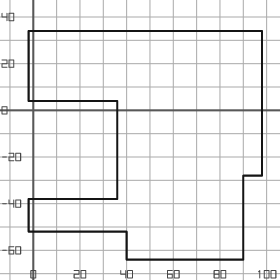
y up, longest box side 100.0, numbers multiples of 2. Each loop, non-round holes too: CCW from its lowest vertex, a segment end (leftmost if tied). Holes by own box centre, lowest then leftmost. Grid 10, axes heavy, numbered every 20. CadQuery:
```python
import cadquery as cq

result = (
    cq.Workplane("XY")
    .moveTo(40.0, -64.0)
    .lineTo(90.0, -64.0)
    .lineTo(90.0, -28.0)
    .lineTo(98.0, -28.0)
    .lineTo(98.0, 34.0)
    .lineTo(-2.0, 34.0)
    .lineTo(-2.0, 4.0)
    .lineTo(36.0, 4.0)
    .lineTo(36.0, -38.0)
    .lineTo(-2.0, -38.0)
    .lineTo(-2.0, -52.0)
    .lineTo(40.0, -52.0)
    .close()
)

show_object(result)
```